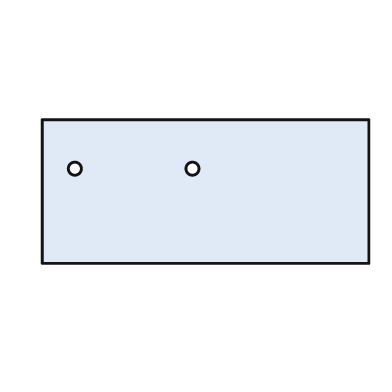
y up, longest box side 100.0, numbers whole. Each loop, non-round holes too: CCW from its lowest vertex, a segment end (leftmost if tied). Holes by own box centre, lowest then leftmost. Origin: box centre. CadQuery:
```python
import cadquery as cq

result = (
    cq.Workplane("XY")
    .moveTo(-50.0, -22.0)
    .lineTo(50.0, -22.0)
    .lineTo(50.0, 22.0)
    .lineTo(-50.0, 22.0)
    .close()
    .moveTo(-40.0, 7.0)
    .circle(2.0)
    .moveTo(-4.0, 7.0)
    .circle(2.0)
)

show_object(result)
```